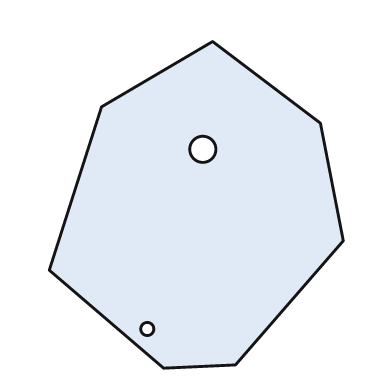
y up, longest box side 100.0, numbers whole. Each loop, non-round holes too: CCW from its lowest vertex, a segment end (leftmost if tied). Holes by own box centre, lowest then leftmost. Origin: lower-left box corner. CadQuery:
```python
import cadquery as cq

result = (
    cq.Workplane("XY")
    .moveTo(35.0, 0.0)
    .lineTo(57.0, 1.0)
    .lineTo(90.0, 39.0)
    .lineTo(83.0, 75.0)
    .lineTo(50.0, 100.0)
    .lineTo(16.0, 80.0)
    .lineTo(0.0, 30.0)
    .close()
    .moveTo(30.0, 12.0)
    .circle(2.0)
    .moveTo(47.0, 67.0)
    .circle(4.0)
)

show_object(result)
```